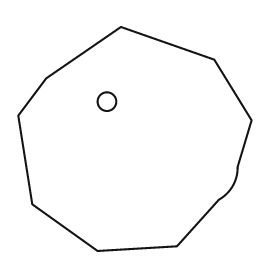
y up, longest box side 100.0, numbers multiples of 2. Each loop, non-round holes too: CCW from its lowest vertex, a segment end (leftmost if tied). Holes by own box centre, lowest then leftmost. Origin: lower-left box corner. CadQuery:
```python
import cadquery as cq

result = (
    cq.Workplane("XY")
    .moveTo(34.0, 0.0)
    .lineTo(68.0, 2.0)
    .lineTo(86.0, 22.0)
    .threePointArc((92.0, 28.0), (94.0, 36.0))
    .lineTo(100.0, 56.0)
    .lineTo(84.0, 82.0)
    .lineTo(44.0, 96.0)
    .lineTo(12.0, 74.0)
    .lineTo(0.0, 58.0)
    .lineTo(6.0, 20.0)
    .close()
    .moveTo(38.0, 64.0)
    .circle(4.0)
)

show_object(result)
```